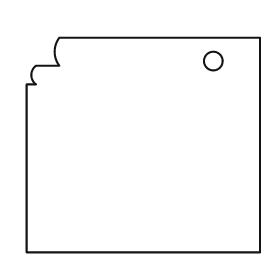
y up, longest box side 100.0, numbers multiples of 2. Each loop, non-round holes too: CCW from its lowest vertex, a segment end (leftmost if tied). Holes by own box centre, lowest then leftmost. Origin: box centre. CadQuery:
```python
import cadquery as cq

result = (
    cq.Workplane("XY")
    .moveTo(-50.0, -46.0)
    .lineTo(50.0, -46.0)
    .lineTo(50.0, 46.0)
    .lineTo(-36.0, 46.0)
    .threePointArc((-38.0, 40.0), (-36.0, 34.0))
    .lineTo(-46.0, 34.0)
    .threePointArc((-48.0, 30.0), (-46.0, 26.0))
    .lineTo(-50.0, 26.0)
    .close()
    .moveTo(30.0, 36.0)
    .circle(4.0)
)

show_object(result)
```